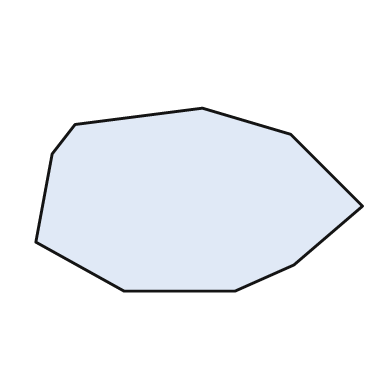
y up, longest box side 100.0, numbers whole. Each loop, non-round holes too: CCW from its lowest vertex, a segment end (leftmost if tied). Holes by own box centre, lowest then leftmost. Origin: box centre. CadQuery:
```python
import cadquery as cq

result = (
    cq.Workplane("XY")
    .moveTo(-23.0, -28.0)
    .lineTo(11.0, -28.0)
    .lineTo(29.0, -20.0)
    .lineTo(50.0, -2.0)
    .lineTo(28.0, 20.0)
    .lineTo(1.0, 28.0)
    .lineTo(-38.0, 23.0)
    .lineTo(-45.0, 14.0)
    .lineTo(-50.0, -13.0)
    .close()
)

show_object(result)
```